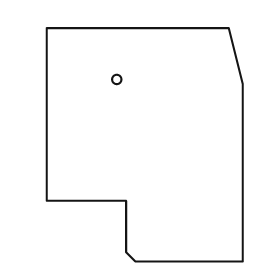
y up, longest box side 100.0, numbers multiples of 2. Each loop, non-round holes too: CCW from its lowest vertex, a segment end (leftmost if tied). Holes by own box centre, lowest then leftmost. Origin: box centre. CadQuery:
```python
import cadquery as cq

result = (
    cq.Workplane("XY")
    .moveTo(-4.0, -50.0)
    .lineTo(42.0, -50.0)
    .lineTo(42.0, 26.0)
    .lineTo(36.0, 50.0)
    .lineTo(-42.0, 50.0)
    .lineTo(-42.0, -24.0)
    .lineTo(-8.0, -24.0)
    .lineTo(-8.0, -46.0)
    .close()
    .moveTo(-12.0, 28.0)
    .circle(2.0)
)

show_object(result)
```